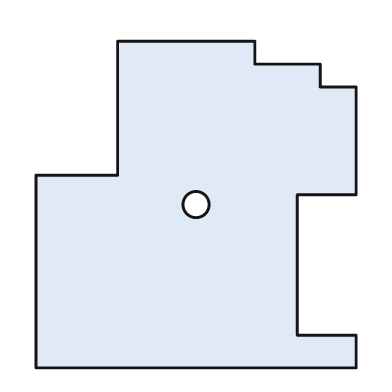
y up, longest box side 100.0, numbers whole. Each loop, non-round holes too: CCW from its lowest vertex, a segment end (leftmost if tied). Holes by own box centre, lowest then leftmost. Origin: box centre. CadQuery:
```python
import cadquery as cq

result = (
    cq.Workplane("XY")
    .moveTo(-49.0, -50.0)
    .lineTo(49.0, -50.0)
    .lineTo(49.0, -40.0)
    .lineTo(31.0, -40.0)
    .lineTo(31.0, 3.0)
    .lineTo(49.0, 3.0)
    .lineTo(49.0, 36.0)
    .lineTo(38.0, 36.0)
    .lineTo(38.0, 43.0)
    .lineTo(18.0, 43.0)
    .lineTo(18.0, 50.0)
    .lineTo(-24.0, 50.0)
    .lineTo(-24.0, 9.0)
    .lineTo(-49.0, 9.0)
    .close()
    .moveTo(0.0, 0.0)
    .circle(4.0)
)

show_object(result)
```